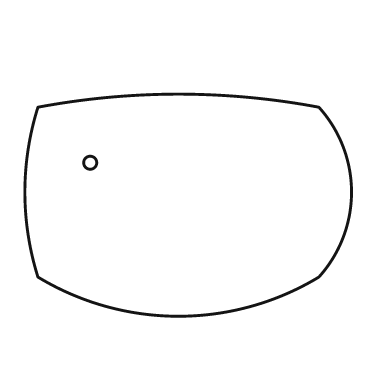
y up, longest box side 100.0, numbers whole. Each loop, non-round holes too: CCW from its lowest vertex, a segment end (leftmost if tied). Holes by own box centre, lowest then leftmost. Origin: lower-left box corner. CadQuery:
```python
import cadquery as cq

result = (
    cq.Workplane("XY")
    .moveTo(4.0, 12.0)
    .threePointArc((47.0, 0.0), (90.0, 12.0))
    .threePointArc((100.0, 38.0), (90.0, 64.0))
    .threePointArc((47.0, 68.0), (4.0, 64.0))
    .threePointArc((0.0, 38.0), (4.0, 12.0))
    .close()
    .moveTo(20.0, 47.0)
    .circle(2.0)
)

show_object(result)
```